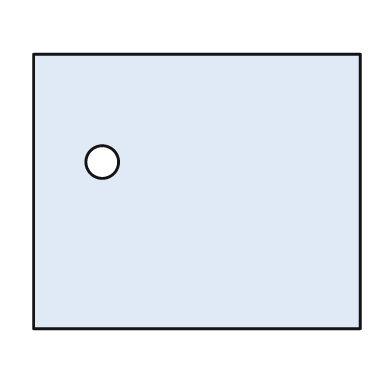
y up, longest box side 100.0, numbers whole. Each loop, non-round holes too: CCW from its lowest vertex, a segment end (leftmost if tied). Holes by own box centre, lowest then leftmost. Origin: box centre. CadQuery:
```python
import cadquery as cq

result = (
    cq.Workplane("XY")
    .moveTo(-50.0, -42.0)
    .lineTo(50.0, -42.0)
    .lineTo(50.0, 42.0)
    .lineTo(-50.0, 42.0)
    .close()
    .moveTo(-29.0, 9.0)
    .circle(5.0)
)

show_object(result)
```